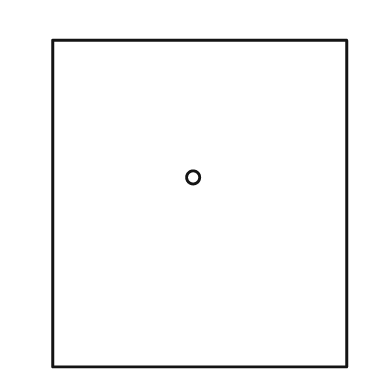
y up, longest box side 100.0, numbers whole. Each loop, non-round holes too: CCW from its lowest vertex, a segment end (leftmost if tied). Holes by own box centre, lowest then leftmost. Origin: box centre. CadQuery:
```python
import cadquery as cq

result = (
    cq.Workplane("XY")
    .moveTo(-45.0, -50.0)
    .lineTo(45.0, -50.0)
    .lineTo(45.0, 50.0)
    .lineTo(-45.0, 50.0)
    .close()
    .moveTo(-2.0, 8.0)
    .circle(2.0)
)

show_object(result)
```